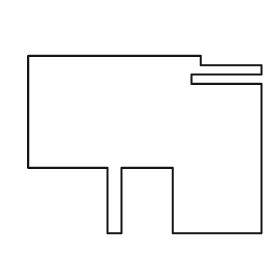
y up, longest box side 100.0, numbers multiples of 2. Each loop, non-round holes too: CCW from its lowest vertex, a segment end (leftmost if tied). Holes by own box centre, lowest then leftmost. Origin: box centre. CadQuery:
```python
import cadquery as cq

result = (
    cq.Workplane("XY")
    .moveTo(-16.0, -38.0)
    .lineTo(-10.0, -38.0)
    .lineTo(-10.0, -10.0)
    .lineTo(12.0, -10.0)
    .lineTo(12.0, -38.0)
    .lineTo(50.0, -38.0)
    .lineTo(50.0, 26.0)
    .lineTo(20.0, 26.0)
    .lineTo(20.0, 30.0)
    .lineTo(50.0, 30.0)
    .lineTo(50.0, 34.0)
    .lineTo(24.0, 34.0)
    .lineTo(24.0, 38.0)
    .lineTo(-50.0, 38.0)
    .lineTo(-50.0, -10.0)
    .lineTo(-16.0, -10.0)
    .close()
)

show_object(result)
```